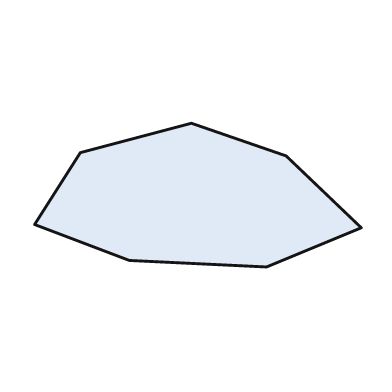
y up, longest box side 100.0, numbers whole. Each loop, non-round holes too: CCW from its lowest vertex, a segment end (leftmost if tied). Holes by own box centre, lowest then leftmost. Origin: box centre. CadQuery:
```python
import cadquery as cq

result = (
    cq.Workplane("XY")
    .moveTo(21.0, -22.0)
    .lineTo(50.0, -10.0)
    .lineTo(27.0, 12.0)
    .lineTo(-2.0, 22.0)
    .lineTo(-36.0, 13.0)
    .lineTo(-50.0, -9.0)
    .lineTo(-21.0, -20.0)
    .close()
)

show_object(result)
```